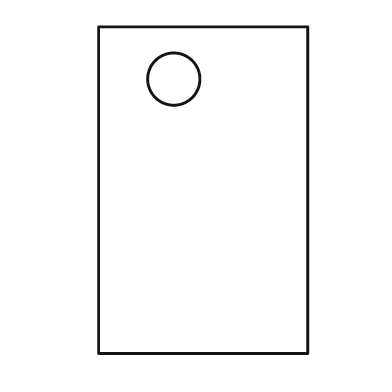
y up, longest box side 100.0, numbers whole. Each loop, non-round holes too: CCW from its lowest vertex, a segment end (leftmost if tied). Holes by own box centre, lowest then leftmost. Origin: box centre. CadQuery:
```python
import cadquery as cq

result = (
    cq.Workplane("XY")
    .moveTo(-32.0, -50.0)
    .lineTo(32.0, -50.0)
    .lineTo(32.0, 50.0)
    .lineTo(-32.0, 50.0)
    .close()
    .moveTo(-9.0, 34.0)
    .circle(8.0)
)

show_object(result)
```